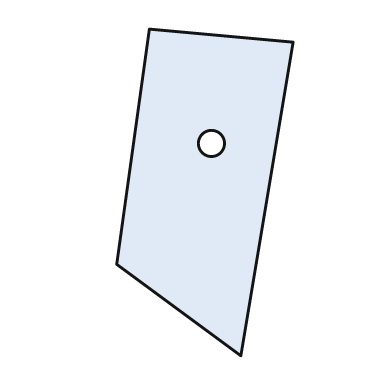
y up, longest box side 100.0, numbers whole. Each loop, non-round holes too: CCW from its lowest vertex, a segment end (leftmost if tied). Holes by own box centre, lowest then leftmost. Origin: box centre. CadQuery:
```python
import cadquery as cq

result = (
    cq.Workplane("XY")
    .moveTo(11.0, -50.0)
    .lineTo(27.0, 46.0)
    .lineTo(-17.0, 50.0)
    .lineTo(-27.0, -22.0)
    .close()
    .moveTo(2.0, 15.0)
    .circle(4.0)
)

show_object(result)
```